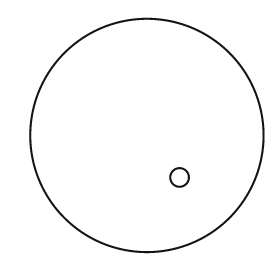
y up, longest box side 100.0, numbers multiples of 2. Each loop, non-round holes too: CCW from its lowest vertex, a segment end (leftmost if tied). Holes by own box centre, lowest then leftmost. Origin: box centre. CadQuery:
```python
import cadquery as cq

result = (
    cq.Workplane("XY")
    .moveTo(0.0, 0.0)
    .circle(50.0)
    .moveTo(14.0, -18.0)
    .circle(4.0)
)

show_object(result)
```